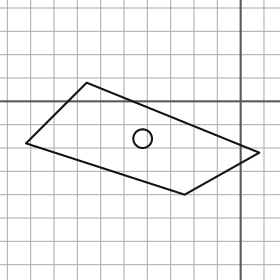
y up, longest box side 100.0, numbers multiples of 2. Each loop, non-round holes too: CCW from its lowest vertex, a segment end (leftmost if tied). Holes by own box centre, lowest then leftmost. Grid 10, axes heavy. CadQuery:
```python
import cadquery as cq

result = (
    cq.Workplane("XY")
    .moveTo(-24.0, -40.0)
    .lineTo(8.0, -22.0)
    .lineTo(-66.0, 8.0)
    .lineTo(-92.0, -18.0)
    .close()
    .moveTo(-42.0, -16.0)
    .circle(4.0)
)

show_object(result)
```